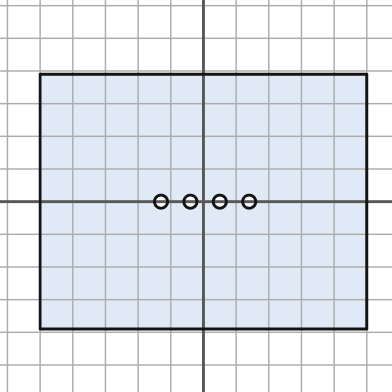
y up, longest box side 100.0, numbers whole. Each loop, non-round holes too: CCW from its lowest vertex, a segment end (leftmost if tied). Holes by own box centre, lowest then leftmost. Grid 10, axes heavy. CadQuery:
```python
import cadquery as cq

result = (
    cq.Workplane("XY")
    .moveTo(-50.0, -39.0)
    .lineTo(50.0, -39.0)
    .lineTo(50.0, 39.0)
    .lineTo(-50.0, 39.0)
    .close()
    .moveTo(-13.0, 0.0)
    .circle(2.0)
    .moveTo(-4.0, 0.0)
    .circle(2.0)
    .moveTo(5.0, 0.0)
    .circle(2.0)
    .moveTo(14.0, 0.0)
    .circle(2.0)
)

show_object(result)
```